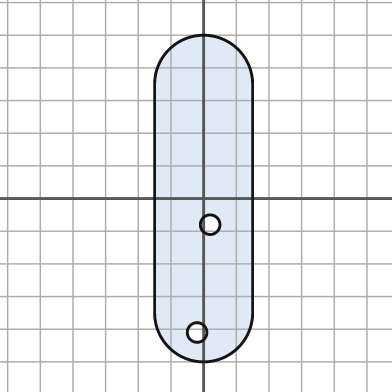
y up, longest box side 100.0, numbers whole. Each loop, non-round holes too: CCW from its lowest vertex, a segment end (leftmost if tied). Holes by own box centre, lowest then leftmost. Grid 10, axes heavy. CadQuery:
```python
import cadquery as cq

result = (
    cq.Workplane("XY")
    .moveTo(-15.0, -35.0)
    .threePointArc((0.0, -50.0), (15.0, -35.0))
    .lineTo(15.0, 35.0)
    .threePointArc((0.0, 50.0), (-15.0, 35.0))
    .close()
    .moveTo(-2.0, -41.0)
    .circle(3.0)
    .moveTo(2.0, -8.0)
    .circle(3.0)
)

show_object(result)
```